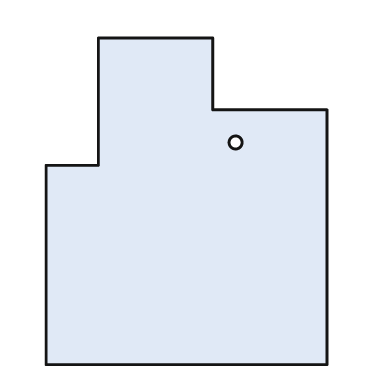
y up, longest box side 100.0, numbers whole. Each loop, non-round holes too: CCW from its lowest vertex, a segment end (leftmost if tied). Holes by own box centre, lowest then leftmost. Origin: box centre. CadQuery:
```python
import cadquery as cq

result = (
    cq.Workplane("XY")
    .moveTo(-43.0, -50.0)
    .lineTo(43.0, -50.0)
    .lineTo(43.0, 28.0)
    .lineTo(8.0, 28.0)
    .lineTo(8.0, 50.0)
    .lineTo(-27.0, 50.0)
    .lineTo(-27.0, 11.0)
    .lineTo(-43.0, 11.0)
    .close()
    .moveTo(15.0, 18.0)
    .circle(2.0)
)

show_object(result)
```